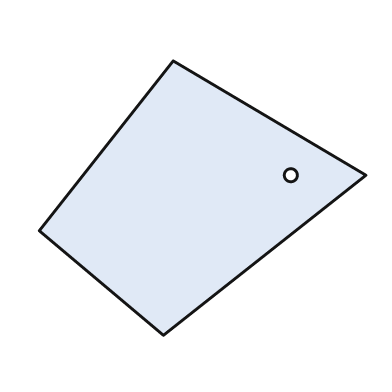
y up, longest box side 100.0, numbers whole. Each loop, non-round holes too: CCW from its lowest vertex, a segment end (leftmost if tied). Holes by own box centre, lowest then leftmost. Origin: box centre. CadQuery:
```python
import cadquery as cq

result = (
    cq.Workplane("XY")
    .moveTo(-12.0, -42.0)
    .lineTo(50.0, 7.0)
    .lineTo(-9.0, 42.0)
    .lineTo(-50.0, -10.0)
    .close()
    .moveTo(27.0, 7.0)
    .circle(2.0)
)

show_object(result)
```